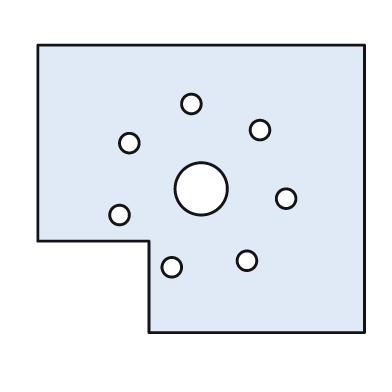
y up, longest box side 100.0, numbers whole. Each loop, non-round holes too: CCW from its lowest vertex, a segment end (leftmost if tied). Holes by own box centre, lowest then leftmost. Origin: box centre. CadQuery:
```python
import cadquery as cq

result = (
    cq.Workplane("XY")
    .moveTo(-16.0, -44.0)
    .lineTo(50.0, -44.0)
    .lineTo(50.0, 44.0)
    .lineTo(-50.0, 44.0)
    .lineTo(-50.0, -16.0)
    .lineTo(-16.0, -16.0)
    .close()
    .moveTo(-9.0, -24.0)
    .circle(3.0)
    .moveTo(14.0, -22.0)
    .circle(3.0)
    .moveTo(-25.0, -8.0)
    .circle(3.0)
    .moveTo(26.0, -3.0)
    .circle(3.0)
    .moveTo(0.0, 0.0)
    .circle(8.0)
    .moveTo(-22.0, 14.0)
    .circle(3.0)
    .moveTo(18.0, 18.0)
    .circle(3.0)
    .moveTo(-3.0, 26.0)
    .circle(3.0)
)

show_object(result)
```